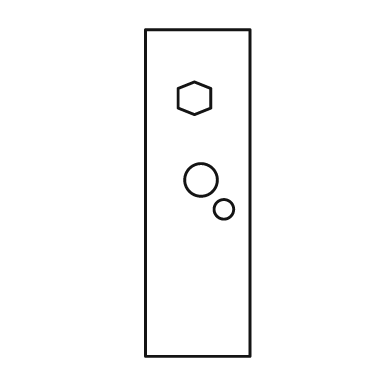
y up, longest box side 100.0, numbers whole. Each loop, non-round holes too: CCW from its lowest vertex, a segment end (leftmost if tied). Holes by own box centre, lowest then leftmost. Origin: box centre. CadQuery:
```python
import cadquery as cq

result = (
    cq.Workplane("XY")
    .moveTo(-16.0, -50.0)
    .lineTo(16.0, -50.0)
    .lineTo(16.0, 50.0)
    .lineTo(-16.0, 50.0)
    .close()
    .moveTo(8.0, -5.0)
    .circle(3.0)
    .moveTo(1.0, 4.0)
    .circle(5.0)
    .moveTo(-1.0, 24.0)
    .lineTo(4.0, 26.0)
    .lineTo(4.0, 32.0)
    .lineTo(-1.0, 34.0)
    .lineTo(-6.0, 32.0)
    .lineTo(-6.0, 26.0)
    .close()
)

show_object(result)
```